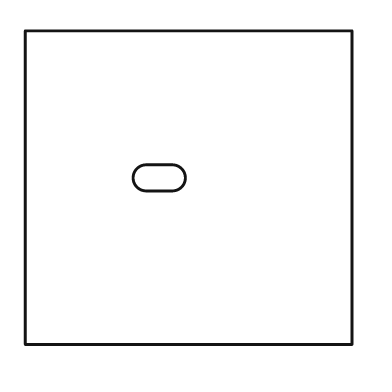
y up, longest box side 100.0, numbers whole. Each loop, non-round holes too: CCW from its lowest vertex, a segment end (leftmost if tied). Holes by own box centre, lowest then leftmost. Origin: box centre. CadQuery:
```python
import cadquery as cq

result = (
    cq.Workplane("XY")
    .moveTo(-50.0, -48.0)
    .lineTo(50.0, -48.0)
    .lineTo(50.0, 48.0)
    .lineTo(-50.0, 48.0)
    .close()
    .moveTo(-13.0, -1.0)
    .lineTo(-5.0, -1.0)
    .threePointArc((-1.0, 3.0), (-5.0, 7.0))
    .lineTo(-13.0, 7.0)
    .threePointArc((-17.0, 3.0), (-13.0, -1.0))
    .close()
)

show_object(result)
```